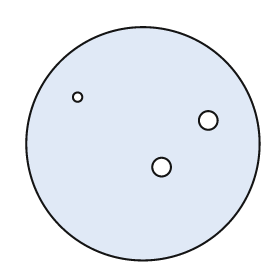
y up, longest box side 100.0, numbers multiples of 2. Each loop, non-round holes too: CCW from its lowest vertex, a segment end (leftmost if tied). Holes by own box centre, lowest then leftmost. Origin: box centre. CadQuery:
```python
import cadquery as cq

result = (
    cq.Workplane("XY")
    .moveTo(0.0, 0.0)
    .circle(50.0)
    .moveTo(8.0, -10.0)
    .circle(4.0)
    .moveTo(28.0, 10.0)
    .circle(4.0)
    .moveTo(-28.0, 20.0)
    .circle(2.0)
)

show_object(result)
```